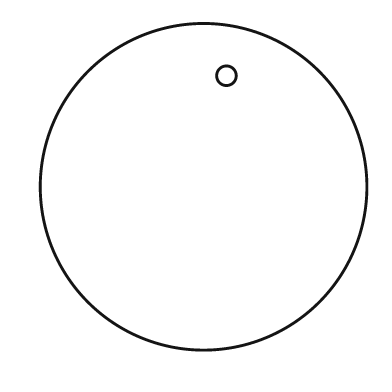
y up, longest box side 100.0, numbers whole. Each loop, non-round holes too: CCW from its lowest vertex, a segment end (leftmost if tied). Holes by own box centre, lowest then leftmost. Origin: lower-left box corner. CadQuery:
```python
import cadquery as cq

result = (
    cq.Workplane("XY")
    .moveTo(50.0, 50.0)
    .circle(50.0)
    .moveTo(57.0, 84.0)
    .circle(3.0)
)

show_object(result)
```